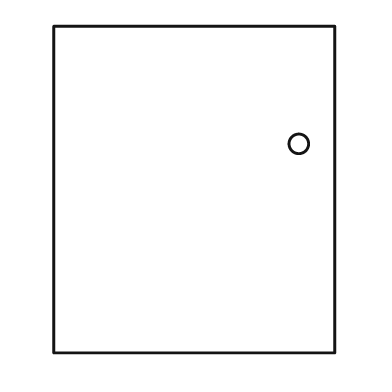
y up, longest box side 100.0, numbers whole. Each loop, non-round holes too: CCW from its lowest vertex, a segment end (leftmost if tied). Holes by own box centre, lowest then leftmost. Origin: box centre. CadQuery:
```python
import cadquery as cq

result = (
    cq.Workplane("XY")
    .moveTo(-43.0, -50.0)
    .lineTo(43.0, -50.0)
    .lineTo(43.0, 50.0)
    .lineTo(-43.0, 50.0)
    .close()
    .moveTo(32.0, 14.0)
    .circle(3.0)
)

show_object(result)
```